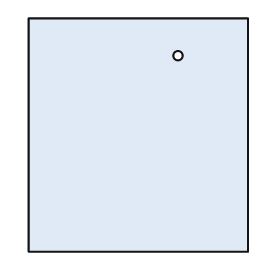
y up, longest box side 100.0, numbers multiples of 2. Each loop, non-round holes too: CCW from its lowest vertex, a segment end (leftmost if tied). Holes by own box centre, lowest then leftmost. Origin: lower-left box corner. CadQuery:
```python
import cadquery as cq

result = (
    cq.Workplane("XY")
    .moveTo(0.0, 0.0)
    .lineTo(94.0, 0.0)
    .lineTo(94.0, 100.0)
    .lineTo(0.0, 100.0)
    .close()
    .moveTo(64.0, 84.0)
    .circle(2.0)
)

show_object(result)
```